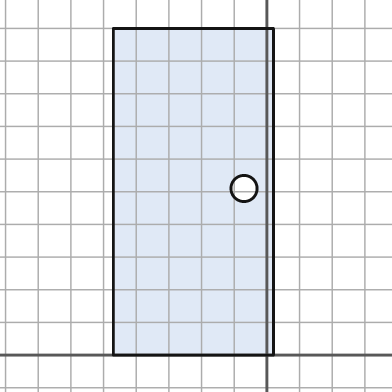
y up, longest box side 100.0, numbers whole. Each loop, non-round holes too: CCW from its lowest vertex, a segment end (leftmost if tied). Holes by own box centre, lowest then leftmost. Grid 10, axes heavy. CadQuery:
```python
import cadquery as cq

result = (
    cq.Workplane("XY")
    .moveTo(-47.0, 0.0)
    .lineTo(2.0, 0.0)
    .lineTo(2.0, 100.0)
    .lineTo(-47.0, 100.0)
    .close()
    .moveTo(-7.0, 51.0)
    .circle(4.0)
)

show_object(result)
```